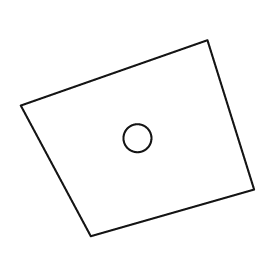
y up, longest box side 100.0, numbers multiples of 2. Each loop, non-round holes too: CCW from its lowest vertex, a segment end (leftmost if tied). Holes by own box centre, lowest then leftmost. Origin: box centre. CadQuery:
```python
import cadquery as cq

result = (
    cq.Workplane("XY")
    .moveTo(-20.0, -42.0)
    .lineTo(50.0, -22.0)
    .lineTo(30.0, 42.0)
    .lineTo(-50.0, 14.0)
    .close()
    .moveTo(0.0, 0.0)
    .circle(6.0)
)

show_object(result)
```